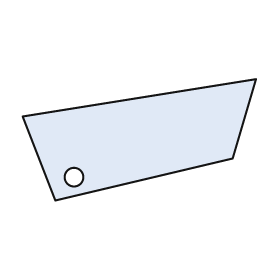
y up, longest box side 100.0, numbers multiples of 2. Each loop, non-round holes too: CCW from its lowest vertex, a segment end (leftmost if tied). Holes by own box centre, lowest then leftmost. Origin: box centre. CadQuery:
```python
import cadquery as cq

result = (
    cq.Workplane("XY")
    .moveTo(-36.0, -26.0)
    .lineTo(40.0, -8.0)
    .lineTo(50.0, 26.0)
    .lineTo(-50.0, 10.0)
    .close()
    .moveTo(-28.0, -16.0)
    .circle(4.0)
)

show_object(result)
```